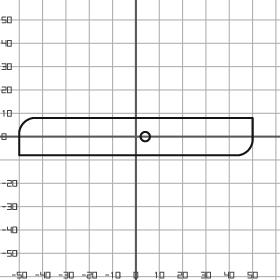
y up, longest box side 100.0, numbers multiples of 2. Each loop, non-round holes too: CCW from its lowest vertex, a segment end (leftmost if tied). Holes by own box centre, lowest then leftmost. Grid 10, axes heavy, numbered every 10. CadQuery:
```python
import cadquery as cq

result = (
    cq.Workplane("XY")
    .moveTo(-50.0, -8.0)
    .lineTo(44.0, -8.0)
    .threePointArc((48.0, -6.0), (50.0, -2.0))
    .lineTo(50.0, 8.0)
    .lineTo(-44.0, 8.0)
    .threePointArc((-48.0, 6.0), (-50.0, 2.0))
    .close()
    .moveTo(4.0, 0.0)
    .circle(2.0)
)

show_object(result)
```